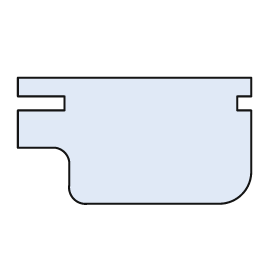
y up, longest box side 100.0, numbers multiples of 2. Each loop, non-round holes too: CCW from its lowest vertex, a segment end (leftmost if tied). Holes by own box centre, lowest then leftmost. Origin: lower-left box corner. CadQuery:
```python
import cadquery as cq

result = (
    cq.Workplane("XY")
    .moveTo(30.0, 0.0)
    .lineTo(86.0, 0.0)
    .threePointArc((96.0, 4.0), (100.0, 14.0))
    .lineTo(100.0, 40.0)
    .lineTo(94.0, 40.0)
    .lineTo(94.0, 46.0)
    .lineTo(100.0, 46.0)
    .lineTo(100.0, 54.0)
    .lineTo(0.0, 54.0)
    .lineTo(0.0, 46.0)
    .lineTo(20.0, 46.0)
    .lineTo(20.0, 40.0)
    .lineTo(0.0, 40.0)
    .lineTo(0.0, 24.0)
    .lineTo(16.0, 24.0)
    .threePointArc((20.0, 22.0), (22.0, 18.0))
    .lineTo(22.0, 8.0)
    .threePointArc((24.0, 2.0), (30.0, 0.0))
    .close()
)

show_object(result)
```